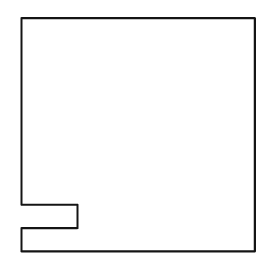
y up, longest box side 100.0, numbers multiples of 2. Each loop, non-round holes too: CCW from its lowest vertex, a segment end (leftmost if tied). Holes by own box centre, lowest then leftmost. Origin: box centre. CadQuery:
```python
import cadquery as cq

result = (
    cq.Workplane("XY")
    .moveTo(-50.0, -50.0)
    .lineTo(50.0, -50.0)
    .lineTo(50.0, 50.0)
    .lineTo(-50.0, 50.0)
    .lineTo(-50.0, -30.0)
    .lineTo(-26.0, -30.0)
    .lineTo(-26.0, -40.0)
    .lineTo(-50.0, -40.0)
    .close()
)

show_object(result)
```